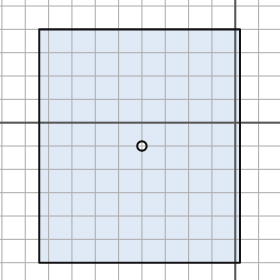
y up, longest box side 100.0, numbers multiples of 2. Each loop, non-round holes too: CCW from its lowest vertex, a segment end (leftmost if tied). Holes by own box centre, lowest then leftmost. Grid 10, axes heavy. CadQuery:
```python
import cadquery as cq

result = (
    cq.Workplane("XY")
    .moveTo(-84.0, -60.0)
    .lineTo(2.0, -60.0)
    .lineTo(2.0, 40.0)
    .lineTo(-84.0, 40.0)
    .close()
    .moveTo(-40.0, -10.0)
    .circle(2.0)
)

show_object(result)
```